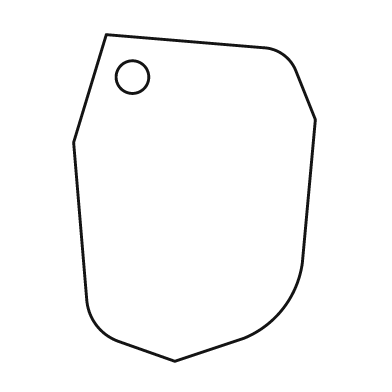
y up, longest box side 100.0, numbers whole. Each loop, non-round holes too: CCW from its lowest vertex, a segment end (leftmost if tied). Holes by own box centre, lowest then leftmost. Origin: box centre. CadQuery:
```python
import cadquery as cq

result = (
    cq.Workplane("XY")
    .moveTo(-6.0, -50.0)
    .lineTo(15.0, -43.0)
    .threePointArc((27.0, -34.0), (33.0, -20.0))
    .lineTo(37.0, 24.0)
    .lineTo(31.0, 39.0)
    .threePointArc((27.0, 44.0), (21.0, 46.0))
    .lineTo(-27.0, 50.0)
    .lineTo(-37.0, 17.0)
    .lineTo(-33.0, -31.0)
    .threePointArc((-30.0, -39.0), (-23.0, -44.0))
    .close()
    .moveTo(-19.0, 37.0)
    .circle(5.0)
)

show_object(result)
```